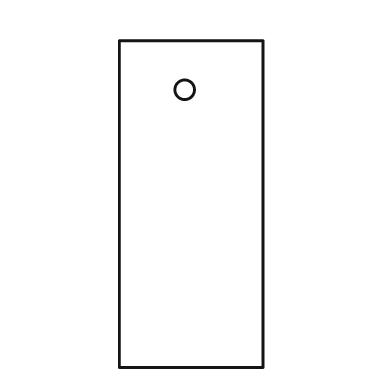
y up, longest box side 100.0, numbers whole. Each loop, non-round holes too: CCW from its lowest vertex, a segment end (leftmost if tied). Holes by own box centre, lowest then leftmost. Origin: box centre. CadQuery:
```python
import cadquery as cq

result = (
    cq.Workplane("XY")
    .moveTo(-22.0, -50.0)
    .lineTo(22.0, -50.0)
    .lineTo(22.0, 50.0)
    .lineTo(-22.0, 50.0)
    .close()
    .moveTo(-2.0, 35.0)
    .circle(3.0)
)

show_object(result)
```